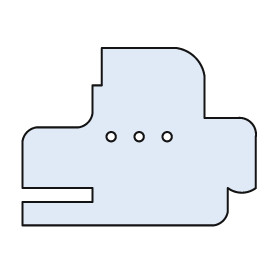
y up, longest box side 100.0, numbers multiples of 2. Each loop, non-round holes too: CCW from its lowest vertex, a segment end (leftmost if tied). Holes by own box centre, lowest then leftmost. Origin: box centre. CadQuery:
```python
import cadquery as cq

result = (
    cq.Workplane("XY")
    .moveTo(-50.0, -38.0)
    .lineTo(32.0, -38.0)
    .threePointArc((36.0, -36.0), (38.0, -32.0))
    .lineTo(38.0, -22.0)
    .threePointArc((44.0, -24.0), (50.0, -22.0))
    .lineTo(50.0, 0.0)
    .threePointArc((48.0, 6.0), (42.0, 8.0))
    .lineTo(28.0, 8.0)
    .lineTo(28.0, 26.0)
    .threePointArc((24.0, 34.0), (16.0, 38.0))
    .lineTo(-16.0, 38.0)
    .lineTo(-16.0, 22.0)
    .lineTo(-20.0, 22.0)
    .lineTo(-20.0, 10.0)
    .threePointArc((-22.0, 6.0), (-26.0, 4.0))
    .lineTo(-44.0, 4.0)
    .threePointArc((-48.0, 2.0), (-50.0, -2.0))
    .lineTo(-50.0, -22.0)
    .lineTo(-20.0, -22.0)
    .lineTo(-20.0, -28.0)
    .lineTo(-50.0, -28.0)
    .close()
    .moveTo(-12.0, 0.0)
    .circle(2.0)
    .moveTo(0.0, 0.0)
    .circle(2.0)
    .moveTo(12.0, 0.0)
    .circle(2.0)
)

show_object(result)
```